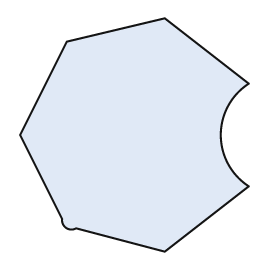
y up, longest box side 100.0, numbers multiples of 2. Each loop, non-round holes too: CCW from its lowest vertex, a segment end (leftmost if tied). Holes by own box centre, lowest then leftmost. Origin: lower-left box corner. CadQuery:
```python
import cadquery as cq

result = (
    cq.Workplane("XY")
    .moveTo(62.0, 0.0)
    .lineTo(98.0, 28.0)
    .threePointArc((86.0, 50.0), (98.0, 72.0))
    .lineTo(62.0, 100.0)
    .lineTo(20.0, 90.0)
    .lineTo(0.0, 50.0)
    .lineTo(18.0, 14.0)
    .threePointArc((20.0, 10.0), (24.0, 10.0))
    .close()
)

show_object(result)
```